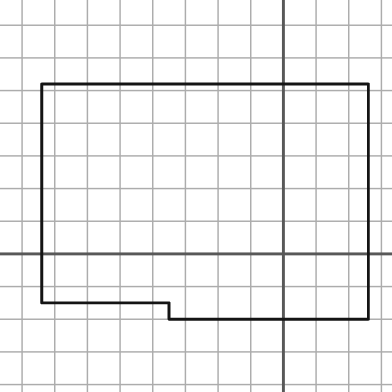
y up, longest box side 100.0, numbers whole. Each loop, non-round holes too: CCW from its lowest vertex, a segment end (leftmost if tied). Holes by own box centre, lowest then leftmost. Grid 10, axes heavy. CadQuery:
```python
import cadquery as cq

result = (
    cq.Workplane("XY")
    .moveTo(-35.0, -20.0)
    .lineTo(26.0, -20.0)
    .lineTo(26.0, 52.0)
    .lineTo(-74.0, 52.0)
    .lineTo(-74.0, -15.0)
    .lineTo(-35.0, -15.0)
    .close()
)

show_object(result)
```